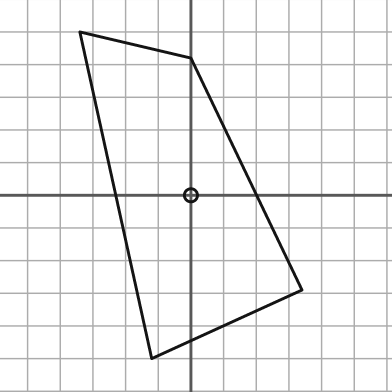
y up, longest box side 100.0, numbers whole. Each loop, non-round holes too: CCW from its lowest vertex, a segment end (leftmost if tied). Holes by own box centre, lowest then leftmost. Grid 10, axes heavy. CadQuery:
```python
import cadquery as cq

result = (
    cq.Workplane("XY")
    .moveTo(-12.0, -50.0)
    .lineTo(34.0, -29.0)
    .lineTo(0.0, 42.0)
    .lineTo(-34.0, 50.0)
    .close()
    .moveTo(0.0, 0.0)
    .circle(2.0)
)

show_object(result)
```